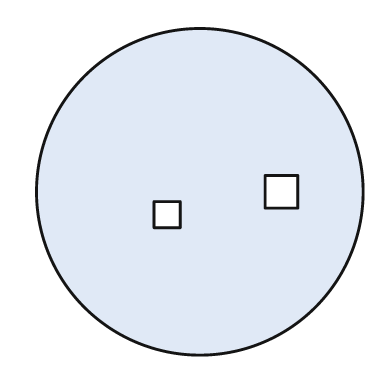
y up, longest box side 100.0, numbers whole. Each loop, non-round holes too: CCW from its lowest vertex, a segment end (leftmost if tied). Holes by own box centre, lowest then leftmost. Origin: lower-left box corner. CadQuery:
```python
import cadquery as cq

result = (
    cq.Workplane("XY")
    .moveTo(50.0, 50.0)
    .circle(50.0)
    .moveTo(36.0, 39.0)
    .lineTo(44.0, 39.0)
    .lineTo(44.0, 47.0)
    .lineTo(36.0, 47.0)
    .close()
    .moveTo(70.0, 45.0)
    .lineTo(80.0, 45.0)
    .lineTo(80.0, 55.0)
    .lineTo(70.0, 55.0)
    .close()
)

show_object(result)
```